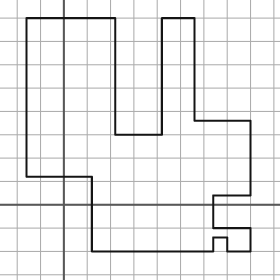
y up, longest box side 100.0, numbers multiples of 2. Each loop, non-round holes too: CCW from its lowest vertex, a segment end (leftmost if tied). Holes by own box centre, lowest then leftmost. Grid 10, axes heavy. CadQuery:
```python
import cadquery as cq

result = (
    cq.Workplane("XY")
    .moveTo(12.0, -20.0)
    .lineTo(64.0, -20.0)
    .lineTo(64.0, -14.0)
    .lineTo(70.0, -14.0)
    .lineTo(70.0, -20.0)
    .lineTo(80.0, -20.0)
    .lineTo(80.0, -10.0)
    .lineTo(64.0, -10.0)
    .lineTo(64.0, 4.0)
    .lineTo(80.0, 4.0)
    .lineTo(80.0, 36.0)
    .lineTo(56.0, 36.0)
    .lineTo(56.0, 80.0)
    .lineTo(42.0, 80.0)
    .lineTo(42.0, 30.0)
    .lineTo(22.0, 30.0)
    .lineTo(22.0, 80.0)
    .lineTo(-16.0, 80.0)
    .lineTo(-16.0, 12.0)
    .lineTo(12.0, 12.0)
    .close()
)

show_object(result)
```